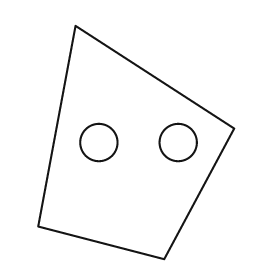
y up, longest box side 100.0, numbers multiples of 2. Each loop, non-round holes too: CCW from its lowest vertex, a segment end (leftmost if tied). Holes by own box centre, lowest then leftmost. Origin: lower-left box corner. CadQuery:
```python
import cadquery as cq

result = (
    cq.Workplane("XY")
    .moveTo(54.0, 0.0)
    .lineTo(84.0, 56.0)
    .lineTo(16.0, 100.0)
    .lineTo(0.0, 14.0)
    .close()
    .moveTo(26.0, 50.0)
    .circle(8.0)
    .moveTo(60.0, 50.0)
    .circle(8.0)
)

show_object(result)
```